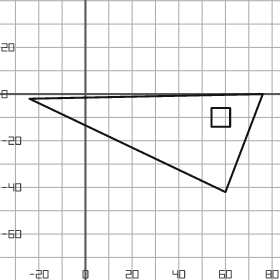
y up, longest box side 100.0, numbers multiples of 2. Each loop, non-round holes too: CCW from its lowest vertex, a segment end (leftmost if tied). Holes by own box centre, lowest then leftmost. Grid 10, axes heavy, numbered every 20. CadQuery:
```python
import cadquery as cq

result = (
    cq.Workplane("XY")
    .moveTo(60.0, -42.0)
    .lineTo(76.0, 0.0)
    .lineTo(-24.0, -2.0)
    .close()
    .moveTo(54.0, -14.0)
    .lineTo(62.0, -14.0)
    .lineTo(62.0, -6.0)
    .lineTo(54.0, -6.0)
    .close()
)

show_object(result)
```